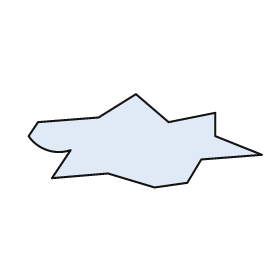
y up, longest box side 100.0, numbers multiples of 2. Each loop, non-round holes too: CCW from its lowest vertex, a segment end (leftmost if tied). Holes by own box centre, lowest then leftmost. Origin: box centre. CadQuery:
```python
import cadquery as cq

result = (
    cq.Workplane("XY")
    .moveTo(4.0, -20.0)
    .lineTo(18.0, -18.0)
    .lineTo(24.0, -8.0)
    .lineTo(50.0, -6.0)
    .lineTo(30.0, 2.0)
    .lineTo(30.0, 12.0)
    .lineTo(10.0, 8.0)
    .lineTo(-4.0, 20.0)
    .lineTo(-20.0, 10.0)
    .lineTo(-46.0, 8.0)
    .lineTo(-50.0, 2.0)
    .threePointArc((-42.0, -4.0), (-32.0, -4.0))
    .lineTo(-40.0, -16.0)
    .lineTo(-16.0, -14.0)
    .close()
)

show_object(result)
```